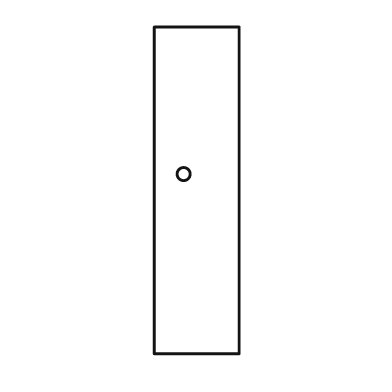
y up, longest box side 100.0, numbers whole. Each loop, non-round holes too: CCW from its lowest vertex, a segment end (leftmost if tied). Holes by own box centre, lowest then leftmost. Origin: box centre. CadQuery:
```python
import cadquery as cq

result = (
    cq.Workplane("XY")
    .moveTo(-13.0, -50.0)
    .lineTo(13.0, -50.0)
    .lineTo(13.0, 50.0)
    .lineTo(-13.0, 50.0)
    .close()
    .moveTo(-4.0, 5.0)
    .circle(2.0)
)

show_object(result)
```